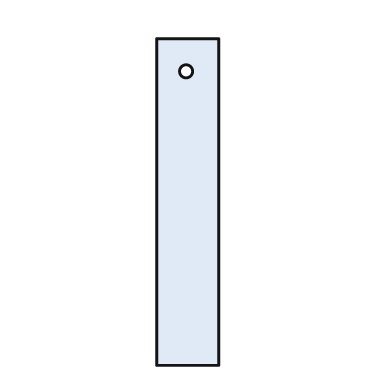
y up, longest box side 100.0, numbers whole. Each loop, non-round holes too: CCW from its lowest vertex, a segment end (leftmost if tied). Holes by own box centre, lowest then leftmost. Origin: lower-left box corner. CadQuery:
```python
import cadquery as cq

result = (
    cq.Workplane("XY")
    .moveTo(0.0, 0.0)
    .lineTo(19.0, 0.0)
    .lineTo(19.0, 100.0)
    .lineTo(0.0, 100.0)
    .close()
    .moveTo(9.0, 90.0)
    .circle(2.0)
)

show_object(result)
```